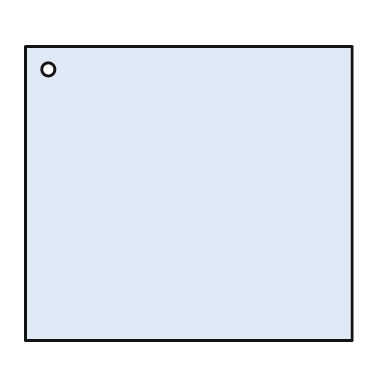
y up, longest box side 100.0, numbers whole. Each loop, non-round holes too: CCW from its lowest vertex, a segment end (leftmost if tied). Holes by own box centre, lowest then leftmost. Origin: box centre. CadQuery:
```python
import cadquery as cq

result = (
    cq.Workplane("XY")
    .moveTo(-50.0, -45.0)
    .lineTo(50.0, -45.0)
    .lineTo(50.0, 45.0)
    .lineTo(-50.0, 45.0)
    .close()
    .moveTo(-43.0, 38.0)
    .circle(2.0)
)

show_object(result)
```